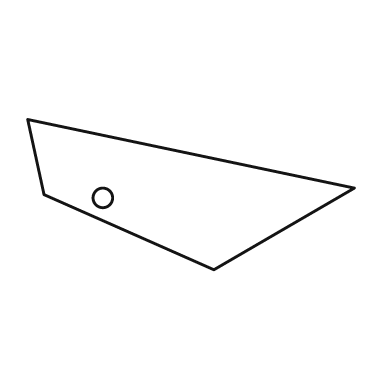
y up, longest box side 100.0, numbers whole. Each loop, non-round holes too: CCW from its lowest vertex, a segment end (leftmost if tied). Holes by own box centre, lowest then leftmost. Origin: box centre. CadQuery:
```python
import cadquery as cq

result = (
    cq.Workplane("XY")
    .moveTo(7.0, -23.0)
    .lineTo(50.0, 2.0)
    .lineTo(-50.0, 23.0)
    .lineTo(-45.0, 0.0)
    .close()
    .moveTo(-27.0, -1.0)
    .circle(3.0)
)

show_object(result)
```